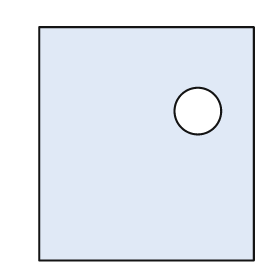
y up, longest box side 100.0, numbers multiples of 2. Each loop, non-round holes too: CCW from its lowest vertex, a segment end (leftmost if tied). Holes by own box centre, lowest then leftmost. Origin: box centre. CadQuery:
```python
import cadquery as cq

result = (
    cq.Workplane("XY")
    .moveTo(-46.0, -50.0)
    .lineTo(46.0, -50.0)
    .lineTo(46.0, 50.0)
    .lineTo(-46.0, 50.0)
    .close()
    .moveTo(22.0, 14.0)
    .circle(10.0)
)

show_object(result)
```